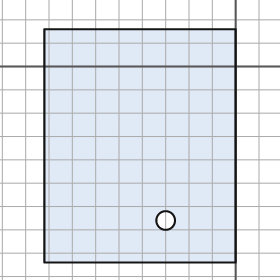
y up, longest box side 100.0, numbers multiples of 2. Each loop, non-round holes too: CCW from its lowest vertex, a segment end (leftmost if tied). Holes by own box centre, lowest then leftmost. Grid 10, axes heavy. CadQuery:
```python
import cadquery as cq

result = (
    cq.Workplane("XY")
    .moveTo(-82.0, -84.0)
    .lineTo(0.0, -84.0)
    .lineTo(0.0, 16.0)
    .lineTo(-82.0, 16.0)
    .close()
    .moveTo(-30.0, -66.0)
    .circle(4.0)
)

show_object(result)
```